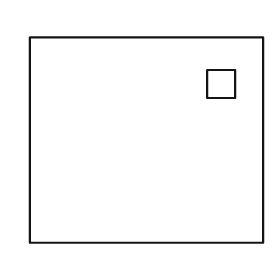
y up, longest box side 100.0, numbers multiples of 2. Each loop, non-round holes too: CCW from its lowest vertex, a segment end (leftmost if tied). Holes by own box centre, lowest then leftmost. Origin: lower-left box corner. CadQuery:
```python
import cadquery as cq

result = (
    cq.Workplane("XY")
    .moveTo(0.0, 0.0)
    .lineTo(100.0, 0.0)
    .lineTo(100.0, 88.0)
    .lineTo(0.0, 88.0)
    .close()
    .moveTo(76.0, 62.0)
    .lineTo(88.0, 62.0)
    .lineTo(88.0, 74.0)
    .lineTo(76.0, 74.0)
    .close()
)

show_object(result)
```